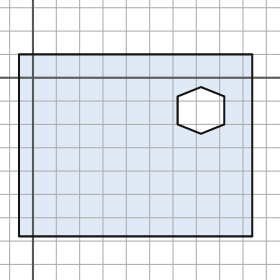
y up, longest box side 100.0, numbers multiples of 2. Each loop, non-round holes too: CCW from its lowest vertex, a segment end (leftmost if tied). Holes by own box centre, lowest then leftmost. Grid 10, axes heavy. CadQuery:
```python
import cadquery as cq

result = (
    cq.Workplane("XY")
    .moveTo(-6.0, -68.0)
    .lineTo(94.0, -68.0)
    .lineTo(94.0, 10.0)
    .lineTo(-6.0, 10.0)
    .close()
    .moveTo(72.0, -24.0)
    .lineTo(82.0, -20.0)
    .lineTo(82.0, -8.0)
    .lineTo(72.0, -4.0)
    .lineTo(62.0, -8.0)
    .lineTo(62.0, -20.0)
    .close()
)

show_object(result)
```